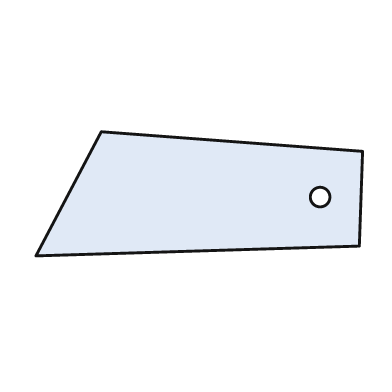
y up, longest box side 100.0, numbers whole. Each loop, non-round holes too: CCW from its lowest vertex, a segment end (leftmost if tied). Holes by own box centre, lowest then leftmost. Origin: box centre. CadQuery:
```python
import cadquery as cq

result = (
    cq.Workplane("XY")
    .moveTo(-50.0, -19.0)
    .lineTo(49.0, -16.0)
    .lineTo(50.0, 13.0)
    .lineTo(-30.0, 19.0)
    .close()
    .moveTo(37.0, -1.0)
    .circle(3.0)
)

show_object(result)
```